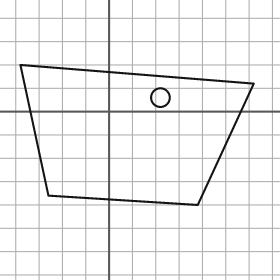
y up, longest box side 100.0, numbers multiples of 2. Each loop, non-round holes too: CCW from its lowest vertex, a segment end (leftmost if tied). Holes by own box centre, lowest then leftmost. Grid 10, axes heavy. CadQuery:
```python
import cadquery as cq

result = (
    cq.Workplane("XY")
    .moveTo(38.0, -40.0)
    .lineTo(62.0, 12.0)
    .lineTo(-38.0, 20.0)
    .lineTo(-26.0, -36.0)
    .close()
    .moveTo(22.0, 6.0)
    .circle(4.0)
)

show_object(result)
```